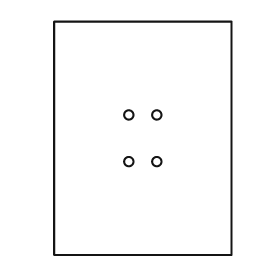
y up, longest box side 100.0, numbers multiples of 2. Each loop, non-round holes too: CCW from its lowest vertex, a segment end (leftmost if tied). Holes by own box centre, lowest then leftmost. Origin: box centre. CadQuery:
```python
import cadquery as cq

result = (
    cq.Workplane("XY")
    .moveTo(-38.0, -50.0)
    .lineTo(38.0, -50.0)
    .lineTo(38.0, 50.0)
    .lineTo(-38.0, 50.0)
    .close()
    .moveTo(-6.0, -10.0)
    .circle(2.0)
    .moveTo(6.0, -10.0)
    .circle(2.0)
    .moveTo(-6.0, 10.0)
    .circle(2.0)
    .moveTo(6.0, 10.0)
    .circle(2.0)
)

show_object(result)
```